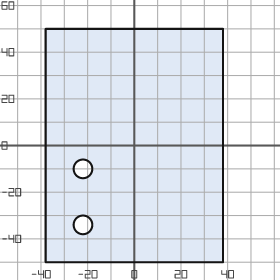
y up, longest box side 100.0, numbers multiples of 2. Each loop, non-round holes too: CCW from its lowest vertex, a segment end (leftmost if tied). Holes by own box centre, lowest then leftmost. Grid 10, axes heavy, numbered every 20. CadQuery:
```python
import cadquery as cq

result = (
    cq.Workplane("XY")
    .moveTo(-38.0, -50.0)
    .lineTo(38.0, -50.0)
    .lineTo(38.0, 50.0)
    .lineTo(-38.0, 50.0)
    .close()
    .moveTo(-22.0, -34.0)
    .circle(4.0)
    .moveTo(-22.0, -10.0)
    .circle(4.0)
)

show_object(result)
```